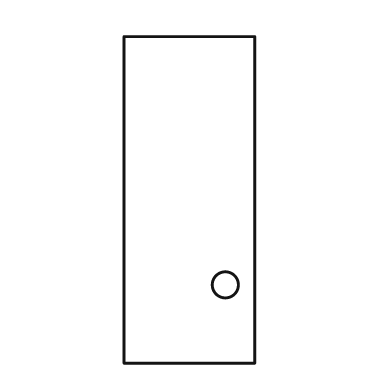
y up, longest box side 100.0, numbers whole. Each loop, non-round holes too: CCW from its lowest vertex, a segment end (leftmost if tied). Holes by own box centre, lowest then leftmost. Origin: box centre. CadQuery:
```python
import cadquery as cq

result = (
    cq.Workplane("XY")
    .moveTo(-20.0, -50.0)
    .lineTo(20.0, -50.0)
    .lineTo(20.0, 50.0)
    .lineTo(-20.0, 50.0)
    .close()
    .moveTo(11.0, -26.0)
    .circle(4.0)
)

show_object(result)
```